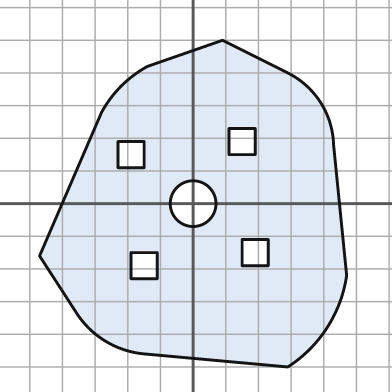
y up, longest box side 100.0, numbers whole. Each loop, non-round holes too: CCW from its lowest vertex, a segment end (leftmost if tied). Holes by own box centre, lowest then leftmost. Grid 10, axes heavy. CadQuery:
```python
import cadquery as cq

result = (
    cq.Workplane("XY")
    .moveTo(29.0, -50.0)
    .threePointArc((41.0, -38.0), (47.0, -22.0))
    .lineTo(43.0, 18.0)
    .threePointArc((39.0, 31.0), (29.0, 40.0))
    .lineTo(9.0, 50.0)
    .lineTo(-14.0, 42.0)
    .threePointArc((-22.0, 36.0), (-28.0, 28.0))
    .lineTo(-47.0, -16.0)
    .lineTo(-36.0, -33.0)
    .threePointArc((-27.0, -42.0), (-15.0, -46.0))
    .close()
    .moveTo(-19.0, -23.0)
    .lineTo(-11.0, -23.0)
    .lineTo(-11.0, -15.0)
    .lineTo(-19.0, -15.0)
    .close()
    .moveTo(15.0, -19.0)
    .lineTo(23.0, -19.0)
    .lineTo(23.0, -11.0)
    .lineTo(15.0, -11.0)
    .close()
    .moveTo(0.0, 0.0)
    .circle(7.0)
    .moveTo(-23.0, 11.0)
    .lineTo(-15.0, 11.0)
    .lineTo(-15.0, 19.0)
    .lineTo(-23.0, 19.0)
    .close()
    .moveTo(11.0, 15.0)
    .lineTo(19.0, 15.0)
    .lineTo(19.0, 23.0)
    .lineTo(11.0, 23.0)
    .close()
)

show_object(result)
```